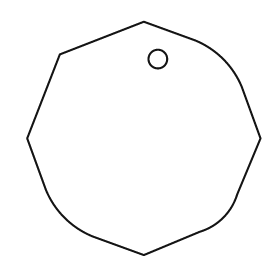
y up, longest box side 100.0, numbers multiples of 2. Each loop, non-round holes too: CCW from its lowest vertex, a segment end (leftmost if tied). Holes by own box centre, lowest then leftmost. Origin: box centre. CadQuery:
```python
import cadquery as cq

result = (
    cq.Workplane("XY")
    .moveTo(0.0, -50.0)
    .lineTo(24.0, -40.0)
    .threePointArc((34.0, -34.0), (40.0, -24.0))
    .lineTo(50.0, 0.0)
    .lineTo(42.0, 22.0)
    .threePointArc((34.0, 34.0), (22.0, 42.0))
    .lineTo(0.0, 50.0)
    .lineTo(-36.0, 36.0)
    .lineTo(-50.0, 0.0)
    .lineTo(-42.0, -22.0)
    .threePointArc((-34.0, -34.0), (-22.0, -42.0))
    .close()
    .moveTo(6.0, 34.0)
    .circle(4.0)
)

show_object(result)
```